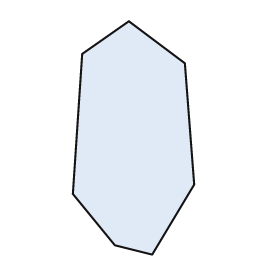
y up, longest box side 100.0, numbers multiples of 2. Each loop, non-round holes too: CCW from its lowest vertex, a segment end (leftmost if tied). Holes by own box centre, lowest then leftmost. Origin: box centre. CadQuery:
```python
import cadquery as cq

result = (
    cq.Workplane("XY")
    .moveTo(8.0, -50.0)
    .lineTo(26.0, -20.0)
    .lineTo(22.0, 32.0)
    .lineTo(-2.0, 50.0)
    .lineTo(-22.0, 36.0)
    .lineTo(-26.0, -24.0)
    .lineTo(-8.0, -46.0)
    .close()
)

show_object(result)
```